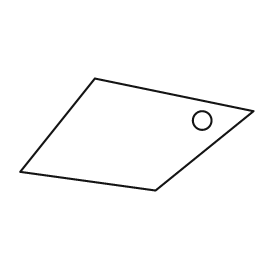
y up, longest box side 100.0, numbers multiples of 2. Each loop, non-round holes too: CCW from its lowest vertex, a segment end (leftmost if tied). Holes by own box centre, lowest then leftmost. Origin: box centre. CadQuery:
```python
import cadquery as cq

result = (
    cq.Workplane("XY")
    .moveTo(8.0, -24.0)
    .lineTo(50.0, 10.0)
    .lineTo(-18.0, 24.0)
    .lineTo(-50.0, -16.0)
    .close()
    .moveTo(28.0, 6.0)
    .circle(4.0)
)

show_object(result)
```